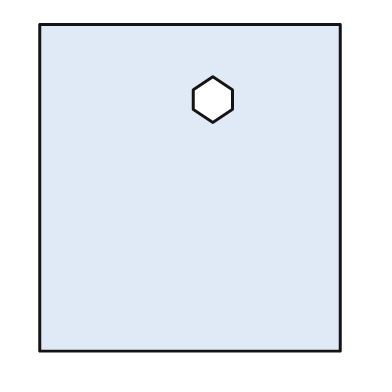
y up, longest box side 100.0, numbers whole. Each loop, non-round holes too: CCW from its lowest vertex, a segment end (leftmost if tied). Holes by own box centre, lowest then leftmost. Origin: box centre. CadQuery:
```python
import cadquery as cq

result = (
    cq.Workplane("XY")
    .moveTo(-46.0, -50.0)
    .lineTo(46.0, -50.0)
    .lineTo(46.0, 50.0)
    .lineTo(-46.0, 50.0)
    .close()
    .moveTo(7.0, 20.0)
    .lineTo(13.0, 24.0)
    .lineTo(13.0, 30.0)
    .lineTo(7.0, 34.0)
    .lineTo(1.0, 30.0)
    .lineTo(1.0, 24.0)
    .close()
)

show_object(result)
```